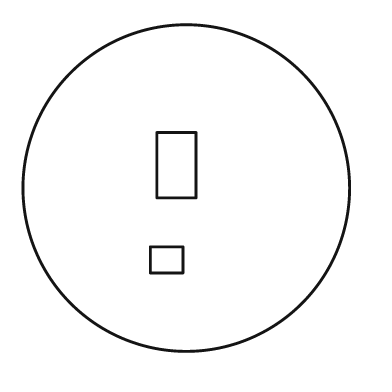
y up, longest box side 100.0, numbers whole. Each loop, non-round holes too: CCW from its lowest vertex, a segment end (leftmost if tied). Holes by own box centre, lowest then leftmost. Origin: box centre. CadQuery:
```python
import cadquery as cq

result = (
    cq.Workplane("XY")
    .moveTo(0.0, 0.0)
    .circle(50.0)
    .moveTo(-11.0, -26.0)
    .lineTo(-1.0, -26.0)
    .lineTo(-1.0, -18.0)
    .lineTo(-11.0, -18.0)
    .close()
    .moveTo(-9.0, -3.0)
    .lineTo(3.0, -3.0)
    .lineTo(3.0, 17.0)
    .lineTo(-9.0, 17.0)
    .close()
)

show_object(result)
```